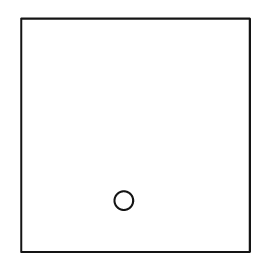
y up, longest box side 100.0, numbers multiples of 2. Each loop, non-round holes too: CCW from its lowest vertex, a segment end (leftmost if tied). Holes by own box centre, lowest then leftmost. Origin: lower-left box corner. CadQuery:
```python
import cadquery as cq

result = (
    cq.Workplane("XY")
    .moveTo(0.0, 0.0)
    .lineTo(98.0, 0.0)
    .lineTo(98.0, 100.0)
    .lineTo(0.0, 100.0)
    .close()
    .moveTo(44.0, 22.0)
    .circle(4.0)
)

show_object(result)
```